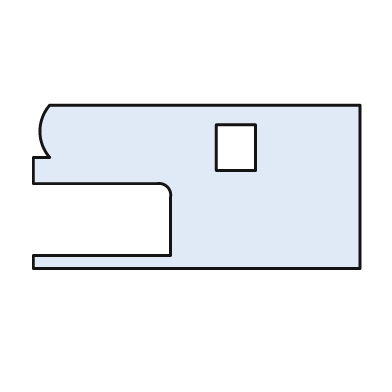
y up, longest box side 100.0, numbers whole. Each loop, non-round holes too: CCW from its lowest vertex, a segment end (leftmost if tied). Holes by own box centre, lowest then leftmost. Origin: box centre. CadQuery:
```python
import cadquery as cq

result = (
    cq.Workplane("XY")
    .moveTo(-50.0, -25.0)
    .lineTo(50.0, -25.0)
    .lineTo(50.0, 25.0)
    .lineTo(-45.0, 25.0)
    .threePointArc((-48.0, 17.0), (-45.0, 9.0))
    .lineTo(-50.0, 9.0)
    .lineTo(-50.0, 1.0)
    .lineTo(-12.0, 1.0)
    .threePointArc((-9.0, 0.0), (-8.0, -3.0))
    .lineTo(-8.0, -21.0)
    .lineTo(-50.0, -21.0)
    .close()
    .moveTo(6.0, 5.0)
    .lineTo(18.0, 5.0)
    .lineTo(18.0, 19.0)
    .lineTo(6.0, 19.0)
    .close()
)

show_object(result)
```